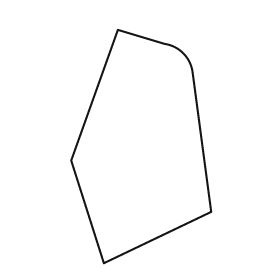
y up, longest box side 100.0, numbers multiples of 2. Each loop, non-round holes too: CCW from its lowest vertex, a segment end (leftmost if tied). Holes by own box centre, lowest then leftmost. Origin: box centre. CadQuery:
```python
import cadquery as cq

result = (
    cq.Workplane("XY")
    .moveTo(-16.0, -50.0)
    .lineTo(30.0, -28.0)
    .lineTo(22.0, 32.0)
    .threePointArc((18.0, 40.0), (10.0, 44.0))
    .lineTo(-10.0, 50.0)
    .lineTo(-30.0, -6.0)
    .close()
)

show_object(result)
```